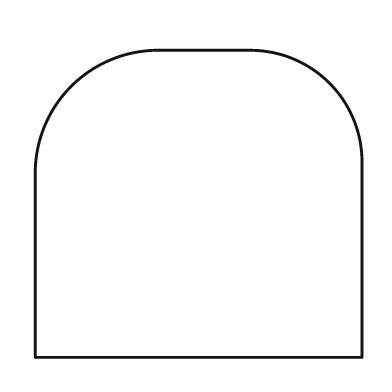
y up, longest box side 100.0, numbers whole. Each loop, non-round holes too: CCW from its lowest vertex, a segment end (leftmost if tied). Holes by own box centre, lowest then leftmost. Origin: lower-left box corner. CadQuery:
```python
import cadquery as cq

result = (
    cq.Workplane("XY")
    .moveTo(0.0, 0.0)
    .lineTo(100.0, 0.0)
    .lineTo(100.0, 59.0)
    .threePointArc((90.0, 84.0), (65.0, 94.0))
    .lineTo(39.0, 94.0)
    .threePointArc((11.0, 83.0), (0.0, 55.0))
    .close()
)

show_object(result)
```